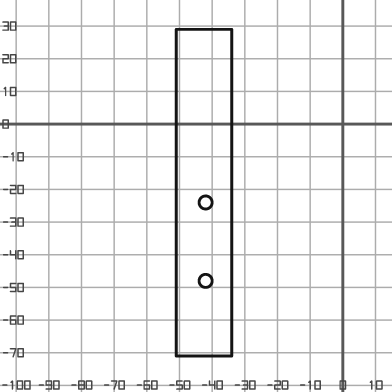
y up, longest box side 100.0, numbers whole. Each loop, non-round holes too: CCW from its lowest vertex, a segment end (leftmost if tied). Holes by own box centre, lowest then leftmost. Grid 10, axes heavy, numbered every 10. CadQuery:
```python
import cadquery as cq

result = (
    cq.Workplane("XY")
    .moveTo(-51.0, -71.0)
    .lineTo(-34.0, -71.0)
    .lineTo(-34.0, 29.0)
    .lineTo(-51.0, 29.0)
    .close()
    .moveTo(-42.0, -48.0)
    .circle(2.0)
    .moveTo(-42.0, -24.0)
    .circle(2.0)
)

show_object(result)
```